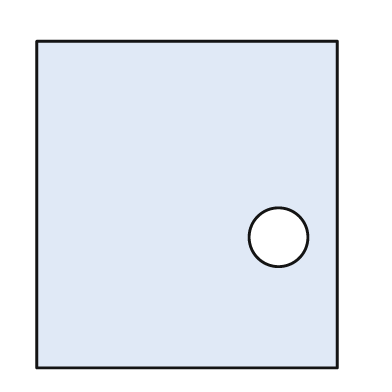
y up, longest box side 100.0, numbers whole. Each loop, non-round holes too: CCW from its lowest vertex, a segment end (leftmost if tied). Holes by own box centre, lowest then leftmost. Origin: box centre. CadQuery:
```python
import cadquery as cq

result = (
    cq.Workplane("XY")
    .moveTo(-46.0, -50.0)
    .lineTo(46.0, -50.0)
    .lineTo(46.0, 50.0)
    .lineTo(-46.0, 50.0)
    .close()
    .moveTo(28.0, -10.0)
    .circle(9.0)
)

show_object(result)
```